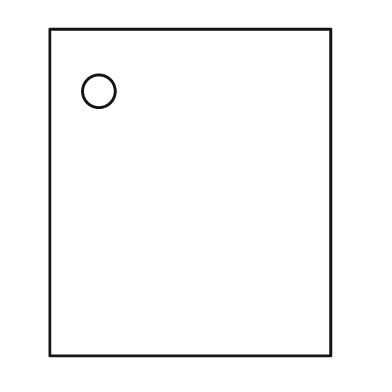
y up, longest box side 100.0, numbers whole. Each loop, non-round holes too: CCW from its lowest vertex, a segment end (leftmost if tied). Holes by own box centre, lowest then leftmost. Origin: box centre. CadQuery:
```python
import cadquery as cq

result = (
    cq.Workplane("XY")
    .moveTo(-43.0, -50.0)
    .lineTo(43.0, -50.0)
    .lineTo(43.0, 50.0)
    .lineTo(-43.0, 50.0)
    .close()
    .moveTo(-28.0, 31.0)
    .circle(5.0)
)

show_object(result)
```